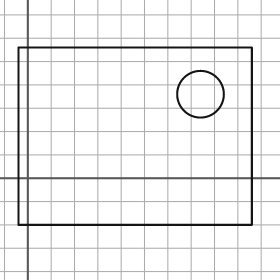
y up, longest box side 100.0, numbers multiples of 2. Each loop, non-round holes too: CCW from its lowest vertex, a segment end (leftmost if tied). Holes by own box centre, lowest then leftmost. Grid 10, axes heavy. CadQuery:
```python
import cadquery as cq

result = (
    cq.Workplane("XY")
    .moveTo(-4.0, -20.0)
    .lineTo(96.0, -20.0)
    .lineTo(96.0, 56.0)
    .lineTo(-4.0, 56.0)
    .close()
    .moveTo(74.0, 36.0)
    .circle(10.0)
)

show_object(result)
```